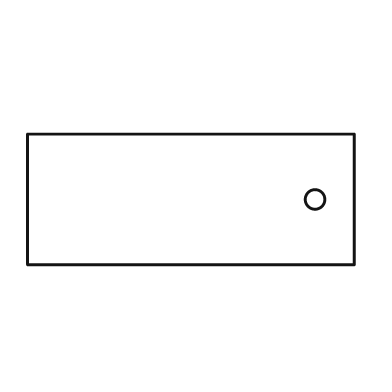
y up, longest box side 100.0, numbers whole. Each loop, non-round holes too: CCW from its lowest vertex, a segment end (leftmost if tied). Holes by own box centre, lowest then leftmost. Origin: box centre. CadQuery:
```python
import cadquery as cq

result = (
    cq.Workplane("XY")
    .moveTo(-50.0, -20.0)
    .lineTo(50.0, -20.0)
    .lineTo(50.0, 20.0)
    .lineTo(-50.0, 20.0)
    .close()
    .moveTo(38.0, 0.0)
    .circle(3.0)
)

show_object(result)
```